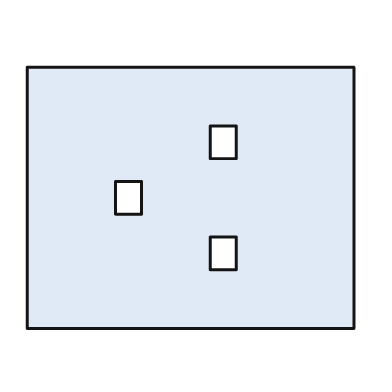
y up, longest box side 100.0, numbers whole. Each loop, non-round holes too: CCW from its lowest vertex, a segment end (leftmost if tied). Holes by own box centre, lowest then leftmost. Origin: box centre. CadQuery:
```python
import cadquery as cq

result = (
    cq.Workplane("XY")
    .moveTo(-50.0, -40.0)
    .lineTo(50.0, -40.0)
    .lineTo(50.0, 40.0)
    .lineTo(-50.0, 40.0)
    .close()
    .moveTo(6.0, -22.0)
    .lineTo(14.0, -22.0)
    .lineTo(14.0, -12.0)
    .lineTo(6.0, -12.0)
    .close()
    .moveTo(-23.0, -5.0)
    .lineTo(-15.0, -5.0)
    .lineTo(-15.0, 5.0)
    .lineTo(-23.0, 5.0)
    .close()
    .moveTo(6.0, 12.0)
    .lineTo(14.0, 12.0)
    .lineTo(14.0, 22.0)
    .lineTo(6.0, 22.0)
    .close()
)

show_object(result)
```